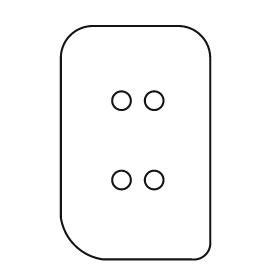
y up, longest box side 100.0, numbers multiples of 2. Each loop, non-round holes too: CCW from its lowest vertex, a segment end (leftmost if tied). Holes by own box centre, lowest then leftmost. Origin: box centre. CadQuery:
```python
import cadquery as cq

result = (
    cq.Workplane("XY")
    .moveTo(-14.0, -50.0)
    .lineTo(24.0, -50.0)
    .threePointArc((30.0, -48.0), (32.0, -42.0))
    .lineTo(32.0, 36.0)
    .threePointArc((28.0, 46.0), (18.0, 50.0))
    .lineTo(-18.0, 50.0)
    .threePointArc((-28.0, 46.0), (-32.0, 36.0))
    .lineTo(-32.0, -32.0)
    .threePointArc((-26.0, -44.0), (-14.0, -50.0))
    .close()
    .moveTo(-6.0, -16.0)
    .circle(4.0)
    .moveTo(8.0, -16.0)
    .circle(4.0)
    .moveTo(-6.0, 18.0)
    .circle(4.0)
    .moveTo(8.0, 18.0)
    .circle(4.0)
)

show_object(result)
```